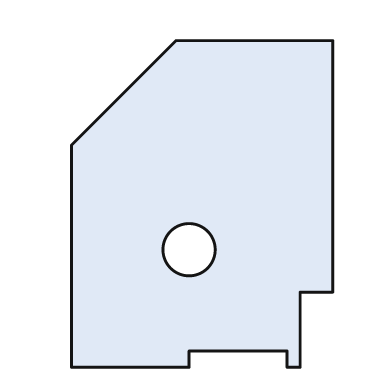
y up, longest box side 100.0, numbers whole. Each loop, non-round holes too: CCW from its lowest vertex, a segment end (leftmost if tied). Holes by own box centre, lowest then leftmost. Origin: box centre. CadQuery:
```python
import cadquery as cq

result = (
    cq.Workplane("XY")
    .moveTo(-40.0, -50.0)
    .lineTo(-4.0, -50.0)
    .lineTo(-4.0, -45.0)
    .lineTo(26.0, -45.0)
    .lineTo(26.0, -50.0)
    .lineTo(30.0, -50.0)
    .lineTo(30.0, -27.0)
    .lineTo(40.0, -27.0)
    .lineTo(40.0, 50.0)
    .lineTo(-8.0, 50.0)
    .lineTo(-40.0, 18.0)
    .close()
    .moveTo(-4.0, -14.0)
    .circle(8.0)
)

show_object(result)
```